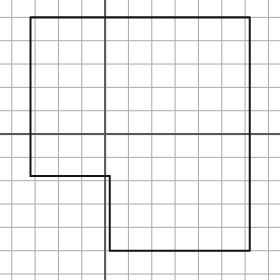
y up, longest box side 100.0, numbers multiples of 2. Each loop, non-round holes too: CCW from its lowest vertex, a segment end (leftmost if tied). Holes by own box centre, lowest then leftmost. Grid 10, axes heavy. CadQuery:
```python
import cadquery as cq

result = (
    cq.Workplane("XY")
    .moveTo(2.0, -50.0)
    .lineTo(62.0, -50.0)
    .lineTo(62.0, 50.0)
    .lineTo(-32.0, 50.0)
    .lineTo(-32.0, -18.0)
    .lineTo(2.0, -18.0)
    .close()
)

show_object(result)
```